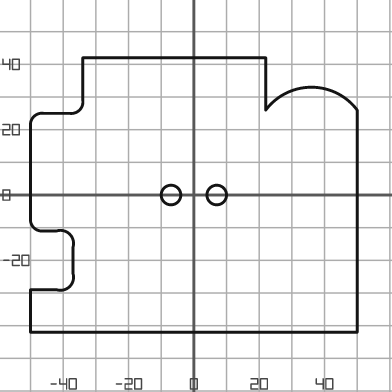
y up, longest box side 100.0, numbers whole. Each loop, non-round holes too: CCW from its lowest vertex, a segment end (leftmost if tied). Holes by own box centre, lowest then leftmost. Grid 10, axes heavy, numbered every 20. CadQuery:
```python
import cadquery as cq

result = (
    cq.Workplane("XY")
    .moveTo(-50.0, -42.0)
    .lineTo(50.0, -42.0)
    .lineTo(50.0, 26.0)
    .threePointArc((36.0, 33.0), (22.0, 26.0))
    .lineTo(22.0, 42.0)
    .lineTo(-34.0, 42.0)
    .lineTo(-34.0, 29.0)
    .threePointArc((-35.0, 26.0), (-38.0, 25.0))
    .lineTo(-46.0, 25.0)
    .threePointArc((-49.0, 24.0), (-50.0, 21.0))
    .lineTo(-50.0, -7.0)
    .threePointArc((-49.0, -10.0), (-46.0, -11.0))
    .lineTo(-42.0, -11.0)
    .threePointArc((-38.0, -12.0), (-37.0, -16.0))
    .lineTo(-37.0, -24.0)
    .threePointArc((-38.0, -28.0), (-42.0, -29.0))
    .lineTo(-50.0, -29.0)
    .close()
    .moveTo(-7.0, 0.0)
    .circle(3.0)
    .moveTo(7.0, 0.0)
    .circle(3.0)
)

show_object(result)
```